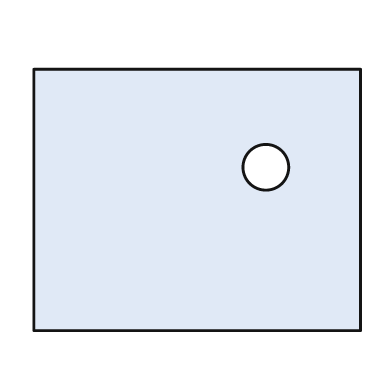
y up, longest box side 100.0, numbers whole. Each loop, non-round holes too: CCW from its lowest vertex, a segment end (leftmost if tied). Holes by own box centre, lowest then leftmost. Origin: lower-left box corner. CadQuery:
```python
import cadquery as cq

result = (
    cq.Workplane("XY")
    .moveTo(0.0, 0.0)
    .lineTo(100.0, 0.0)
    .lineTo(100.0, 80.0)
    .lineTo(0.0, 80.0)
    .close()
    .moveTo(71.0, 50.0)
    .circle(7.0)
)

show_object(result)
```